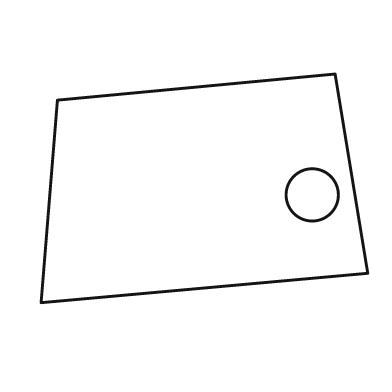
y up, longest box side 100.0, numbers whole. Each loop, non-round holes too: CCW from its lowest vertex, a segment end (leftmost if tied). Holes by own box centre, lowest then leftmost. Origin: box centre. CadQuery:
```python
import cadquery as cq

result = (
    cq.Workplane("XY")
    .moveTo(-50.0, -35.0)
    .lineTo(50.0, -26.0)
    .lineTo(40.0, 35.0)
    .lineTo(-45.0, 27.0)
    .close()
    .moveTo(33.0, -2.0)
    .circle(8.0)
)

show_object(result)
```